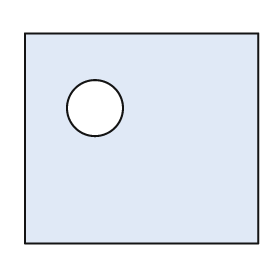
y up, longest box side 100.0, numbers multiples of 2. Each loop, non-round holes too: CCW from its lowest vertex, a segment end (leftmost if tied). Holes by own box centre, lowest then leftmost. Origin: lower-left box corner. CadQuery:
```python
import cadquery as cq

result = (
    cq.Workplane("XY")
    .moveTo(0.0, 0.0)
    .lineTo(100.0, 0.0)
    .lineTo(100.0, 90.0)
    .lineTo(0.0, 90.0)
    .close()
    .moveTo(30.0, 58.0)
    .circle(12.0)
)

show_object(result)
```